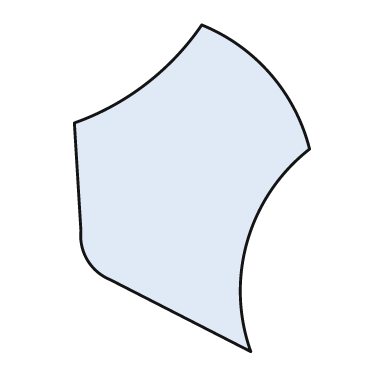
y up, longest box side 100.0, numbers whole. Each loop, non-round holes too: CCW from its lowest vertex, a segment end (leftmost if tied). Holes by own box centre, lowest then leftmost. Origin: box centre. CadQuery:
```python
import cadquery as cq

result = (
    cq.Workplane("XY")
    .moveTo(18.0, -50.0)
    .threePointArc((17.0, -16.0), (36.0, 12.0))
    .threePointArc((24.0, 35.0), (3.0, 50.0))
    .threePointArc((-14.0, 32.0), (-36.0, 20.0))
    .lineTo(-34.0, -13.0)
    .threePointArc((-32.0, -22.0), (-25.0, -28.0))
    .close()
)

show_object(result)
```